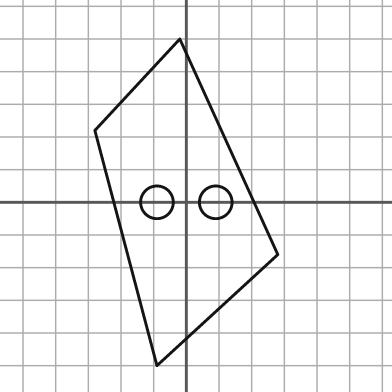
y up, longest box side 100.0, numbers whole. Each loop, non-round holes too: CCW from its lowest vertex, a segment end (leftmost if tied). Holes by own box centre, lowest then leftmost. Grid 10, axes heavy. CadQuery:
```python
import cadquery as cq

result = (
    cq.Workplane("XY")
    .moveTo(-9.0, -50.0)
    .lineTo(28.0, -16.0)
    .lineTo(-2.0, 50.0)
    .lineTo(-28.0, 22.0)
    .close()
    .moveTo(-9.0, 0.0)
    .circle(5.0)
    .moveTo(9.0, 0.0)
    .circle(5.0)
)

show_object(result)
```